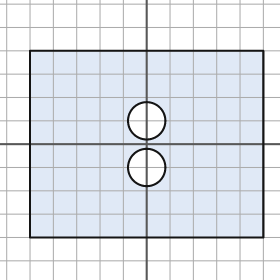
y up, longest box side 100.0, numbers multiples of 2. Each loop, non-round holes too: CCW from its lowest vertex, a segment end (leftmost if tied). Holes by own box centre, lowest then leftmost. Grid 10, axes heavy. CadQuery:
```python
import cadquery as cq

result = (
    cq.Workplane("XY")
    .moveTo(-50.0, -40.0)
    .lineTo(50.0, -40.0)
    .lineTo(50.0, 40.0)
    .lineTo(-50.0, 40.0)
    .close()
    .moveTo(0.0, -10.0)
    .circle(8.0)
    .moveTo(0.0, 10.0)
    .circle(8.0)
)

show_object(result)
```